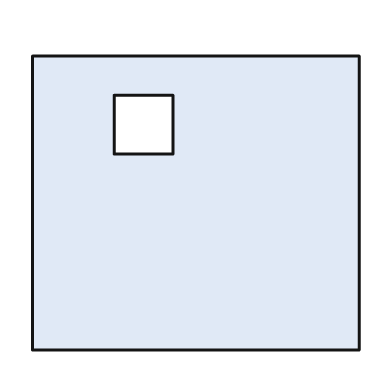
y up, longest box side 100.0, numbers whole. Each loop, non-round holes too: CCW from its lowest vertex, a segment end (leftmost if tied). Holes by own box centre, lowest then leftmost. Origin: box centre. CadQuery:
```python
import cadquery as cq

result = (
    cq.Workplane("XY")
    .moveTo(-50.0, -45.0)
    .lineTo(50.0, -45.0)
    .lineTo(50.0, 45.0)
    .lineTo(-50.0, 45.0)
    .close()
    .moveTo(-25.0, 15.0)
    .lineTo(-7.0, 15.0)
    .lineTo(-7.0, 33.0)
    .lineTo(-25.0, 33.0)
    .close()
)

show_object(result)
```